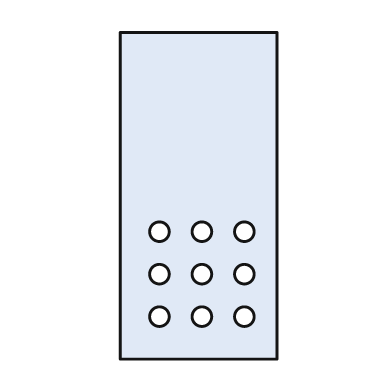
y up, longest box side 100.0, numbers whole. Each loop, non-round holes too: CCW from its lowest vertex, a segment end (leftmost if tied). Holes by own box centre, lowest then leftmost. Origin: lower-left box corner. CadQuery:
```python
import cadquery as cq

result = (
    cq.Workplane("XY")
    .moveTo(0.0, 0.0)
    .lineTo(48.0, 0.0)
    .lineTo(48.0, 100.0)
    .lineTo(0.0, 100.0)
    .close()
    .moveTo(12.0, 13.0)
    .circle(3.0)
    .moveTo(25.0, 13.0)
    .circle(3.0)
    .moveTo(38.0, 13.0)
    .circle(3.0)
    .moveTo(12.0, 26.0)
    .circle(3.0)
    .moveTo(25.0, 26.0)
    .circle(3.0)
    .moveTo(38.0, 26.0)
    .circle(3.0)
    .moveTo(12.0, 39.0)
    .circle(3.0)
    .moveTo(25.0, 39.0)
    .circle(3.0)
    .moveTo(38.0, 39.0)
    .circle(3.0)
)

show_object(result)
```